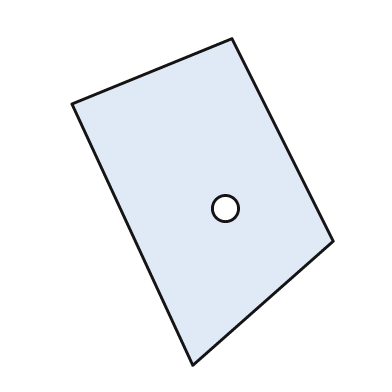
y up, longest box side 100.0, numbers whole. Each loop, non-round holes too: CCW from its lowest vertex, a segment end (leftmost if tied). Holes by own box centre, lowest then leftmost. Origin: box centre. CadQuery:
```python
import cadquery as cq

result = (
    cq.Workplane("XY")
    .moveTo(-3.0, -50.0)
    .lineTo(40.0, -12.0)
    .lineTo(9.0, 50.0)
    .lineTo(-40.0, 30.0)
    .close()
    .moveTo(7.0, -2.0)
    .circle(4.0)
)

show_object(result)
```